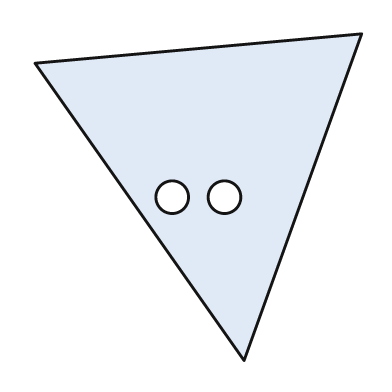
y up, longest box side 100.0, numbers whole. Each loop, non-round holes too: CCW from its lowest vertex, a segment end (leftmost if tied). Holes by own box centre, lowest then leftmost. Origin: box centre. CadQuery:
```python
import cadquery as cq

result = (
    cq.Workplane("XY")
    .moveTo(14.0, -50.0)
    .lineTo(50.0, 50.0)
    .lineTo(-50.0, 41.0)
    .close()
    .moveTo(-8.0, 0.0)
    .circle(5.0)
    .moveTo(8.0, 0.0)
    .circle(5.0)
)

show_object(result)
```